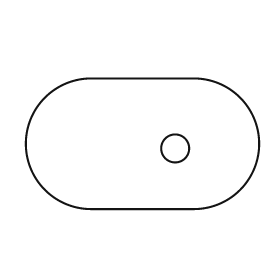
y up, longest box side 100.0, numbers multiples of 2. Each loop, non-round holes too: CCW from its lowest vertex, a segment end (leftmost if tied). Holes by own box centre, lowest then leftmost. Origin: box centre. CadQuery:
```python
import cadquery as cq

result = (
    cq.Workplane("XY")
    .moveTo(-22.0, -28.0)
    .lineTo(22.0, -28.0)
    .threePointArc((50.0, 0.0), (22.0, 28.0))
    .lineTo(-22.0, 28.0)
    .threePointArc((-50.0, 0.0), (-22.0, -28.0))
    .close()
    .moveTo(14.0, -2.0)
    .circle(6.0)
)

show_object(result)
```